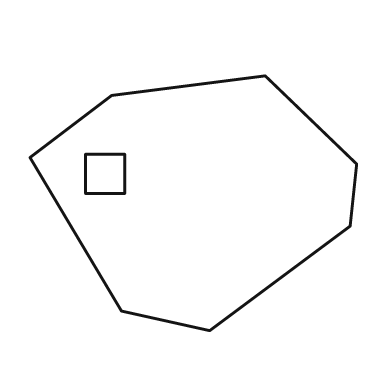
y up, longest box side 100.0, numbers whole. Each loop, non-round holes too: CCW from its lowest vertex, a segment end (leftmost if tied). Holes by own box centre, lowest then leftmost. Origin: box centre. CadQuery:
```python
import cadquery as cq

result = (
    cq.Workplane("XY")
    .moveTo(5.0, -39.0)
    .lineTo(48.0, -7.0)
    .lineTo(50.0, 12.0)
    .lineTo(22.0, 39.0)
    .lineTo(-25.0, 33.0)
    .lineTo(-50.0, 14.0)
    .lineTo(-22.0, -33.0)
    .close()
    .moveTo(-33.0, 3.0)
    .lineTo(-21.0, 3.0)
    .lineTo(-21.0, 15.0)
    .lineTo(-33.0, 15.0)
    .close()
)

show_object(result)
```